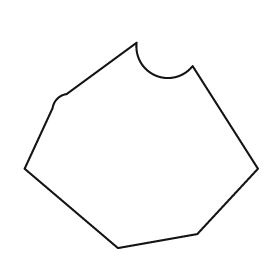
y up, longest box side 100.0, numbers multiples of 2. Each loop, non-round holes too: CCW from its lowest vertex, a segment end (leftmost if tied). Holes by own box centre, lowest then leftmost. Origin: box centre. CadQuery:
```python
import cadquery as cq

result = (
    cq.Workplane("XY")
    .moveTo(-10.0, -44.0)
    .lineTo(24.0, -38.0)
    .lineTo(50.0, -10.0)
    .lineTo(22.0, 34.0)
    .threePointArc((6.0, 30.0), (-2.0, 44.0))
    .lineTo(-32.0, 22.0)
    .threePointArc((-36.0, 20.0), (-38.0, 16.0))
    .lineTo(-50.0, -10.0)
    .close()
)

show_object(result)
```